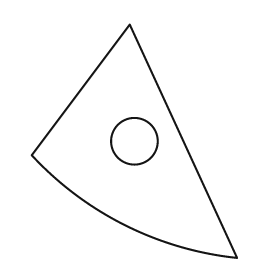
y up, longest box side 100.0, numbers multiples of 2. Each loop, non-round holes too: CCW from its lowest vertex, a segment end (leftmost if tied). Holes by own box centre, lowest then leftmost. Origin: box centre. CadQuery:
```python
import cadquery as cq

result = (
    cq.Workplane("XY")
    .moveTo(44.0, -50.0)
    .lineTo(-2.0, 50.0)
    .lineTo(-44.0, -6.0)
    .threePointArc((-4.0, -36.0), (44.0, -50.0))
    .close()
    .moveTo(0.0, 0.0)
    .circle(10.0)
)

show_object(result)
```